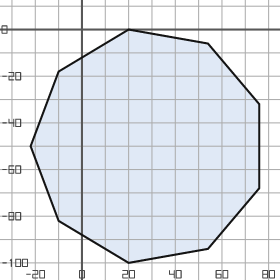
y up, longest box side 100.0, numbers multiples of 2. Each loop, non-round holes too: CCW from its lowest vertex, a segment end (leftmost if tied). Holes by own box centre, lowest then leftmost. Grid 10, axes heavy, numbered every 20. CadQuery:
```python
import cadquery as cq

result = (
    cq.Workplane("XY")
    .moveTo(20.0, -100.0)
    .lineTo(54.0, -94.0)
    .lineTo(76.0, -68.0)
    .lineTo(76.0, -32.0)
    .lineTo(54.0, -6.0)
    .lineTo(20.0, 0.0)
    .lineTo(-10.0, -18.0)
    .lineTo(-22.0, -50.0)
    .lineTo(-10.0, -82.0)
    .close()
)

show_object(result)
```